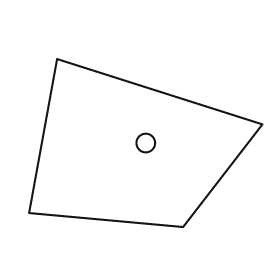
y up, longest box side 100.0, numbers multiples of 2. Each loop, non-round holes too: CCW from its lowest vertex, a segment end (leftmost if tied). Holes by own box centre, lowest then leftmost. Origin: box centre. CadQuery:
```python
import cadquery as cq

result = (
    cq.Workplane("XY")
    .moveTo(16.0, -36.0)
    .lineTo(50.0, 8.0)
    .lineTo(-38.0, 36.0)
    .lineTo(-50.0, -30.0)
    .close()
    .moveTo(0.0, 0.0)
    .circle(4.0)
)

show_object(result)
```